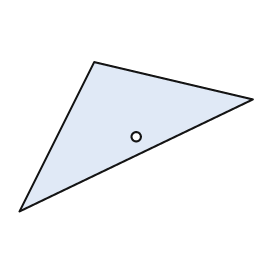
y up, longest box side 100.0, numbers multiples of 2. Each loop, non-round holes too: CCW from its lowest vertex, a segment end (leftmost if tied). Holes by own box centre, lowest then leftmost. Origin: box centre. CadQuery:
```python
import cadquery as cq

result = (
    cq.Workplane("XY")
    .moveTo(-50.0, -32.0)
    .lineTo(50.0, 16.0)
    .lineTo(-18.0, 32.0)
    .close()
    .moveTo(0.0, 0.0)
    .circle(2.0)
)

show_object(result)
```